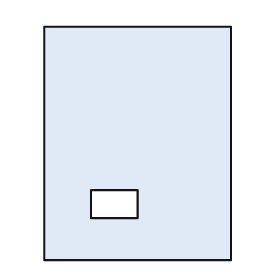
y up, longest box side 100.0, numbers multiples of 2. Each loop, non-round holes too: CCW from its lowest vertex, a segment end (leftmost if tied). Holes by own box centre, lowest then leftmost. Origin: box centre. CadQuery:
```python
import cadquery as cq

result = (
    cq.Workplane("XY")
    .moveTo(-40.0, -50.0)
    .lineTo(40.0, -50.0)
    .lineTo(40.0, 50.0)
    .lineTo(-40.0, 50.0)
    .close()
    .moveTo(-20.0, -32.0)
    .lineTo(0.0, -32.0)
    .lineTo(0.0, -20.0)
    .lineTo(-20.0, -20.0)
    .close()
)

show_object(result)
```